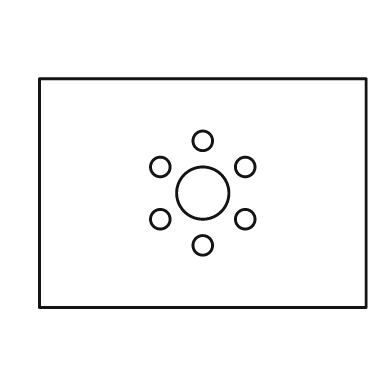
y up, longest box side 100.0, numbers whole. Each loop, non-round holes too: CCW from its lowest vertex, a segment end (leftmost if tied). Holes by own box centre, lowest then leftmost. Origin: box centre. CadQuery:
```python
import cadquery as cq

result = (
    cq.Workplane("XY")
    .moveTo(-50.0, -35.0)
    .lineTo(50.0, -35.0)
    .lineTo(50.0, 35.0)
    .lineTo(-50.0, 35.0)
    .close()
    .moveTo(0.0, -16.0)
    .circle(3.0)
    .moveTo(-13.0, -8.0)
    .circle(3.0)
    .moveTo(13.0, -8.0)
    .circle(3.0)
    .moveTo(0.0, 0.0)
    .circle(8.0)
    .moveTo(-13.0, 8.0)
    .circle(3.0)
    .moveTo(13.0, 8.0)
    .circle(3.0)
    .moveTo(0.0, 16.0)
    .circle(3.0)
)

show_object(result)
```